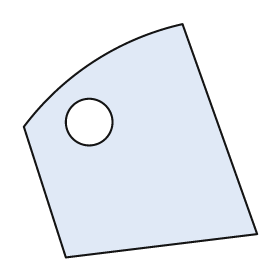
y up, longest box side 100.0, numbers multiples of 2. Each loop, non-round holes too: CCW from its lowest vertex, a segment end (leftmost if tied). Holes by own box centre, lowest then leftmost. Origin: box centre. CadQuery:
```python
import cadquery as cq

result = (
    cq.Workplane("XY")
    .moveTo(-32.0, -50.0)
    .lineTo(50.0, -40.0)
    .lineTo(18.0, 50.0)
    .threePointArc((-20.0, 34.0), (-50.0, 6.0))
    .close()
    .moveTo(-22.0, 8.0)
    .circle(10.0)
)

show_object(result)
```